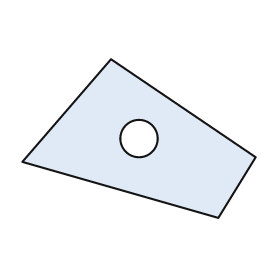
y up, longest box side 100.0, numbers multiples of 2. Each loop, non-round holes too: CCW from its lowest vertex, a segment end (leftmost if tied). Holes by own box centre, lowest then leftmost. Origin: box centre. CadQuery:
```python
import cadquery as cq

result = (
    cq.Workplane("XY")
    .moveTo(34.0, -34.0)
    .lineTo(50.0, -8.0)
    .lineTo(-12.0, 34.0)
    .lineTo(-50.0, -10.0)
    .close()
    .moveTo(0.0, 0.0)
    .circle(8.0)
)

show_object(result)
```